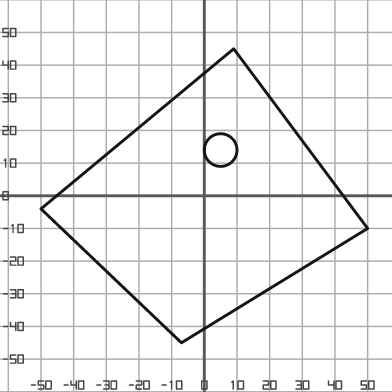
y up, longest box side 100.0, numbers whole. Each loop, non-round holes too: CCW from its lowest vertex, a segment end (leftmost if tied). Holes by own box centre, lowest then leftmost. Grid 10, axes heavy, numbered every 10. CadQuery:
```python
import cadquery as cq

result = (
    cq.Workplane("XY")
    .moveTo(-7.0, -45.0)
    .lineTo(50.0, -10.0)
    .lineTo(9.0, 45.0)
    .lineTo(-50.0, -4.0)
    .close()
    .moveTo(5.0, 14.0)
    .circle(5.0)
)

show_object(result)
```